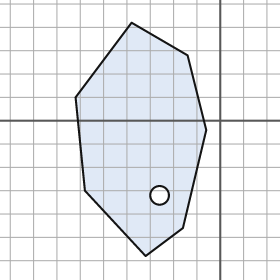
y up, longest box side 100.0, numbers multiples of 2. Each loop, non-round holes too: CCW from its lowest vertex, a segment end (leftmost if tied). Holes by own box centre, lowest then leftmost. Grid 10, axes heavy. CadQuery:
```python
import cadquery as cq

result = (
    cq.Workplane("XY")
    .moveTo(-32.0, -58.0)
    .lineTo(-16.0, -46.0)
    .lineTo(-6.0, -4.0)
    .lineTo(-14.0, 28.0)
    .lineTo(-38.0, 42.0)
    .lineTo(-62.0, 10.0)
    .lineTo(-58.0, -30.0)
    .close()
    .moveTo(-26.0, -32.0)
    .circle(4.0)
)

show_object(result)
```